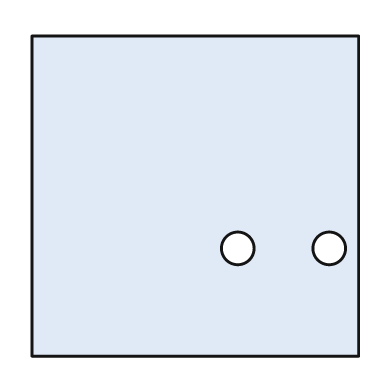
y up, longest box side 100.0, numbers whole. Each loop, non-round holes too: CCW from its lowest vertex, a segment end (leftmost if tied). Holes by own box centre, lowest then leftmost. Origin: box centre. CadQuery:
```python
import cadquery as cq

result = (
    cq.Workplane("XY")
    .moveTo(-50.0, -49.0)
    .lineTo(50.0, -49.0)
    .lineTo(50.0, 49.0)
    .lineTo(-50.0, 49.0)
    .close()
    .moveTo(13.0, -16.0)
    .circle(5.0)
    .moveTo(41.0, -16.0)
    .circle(5.0)
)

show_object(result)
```